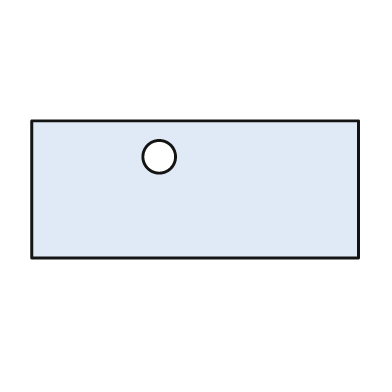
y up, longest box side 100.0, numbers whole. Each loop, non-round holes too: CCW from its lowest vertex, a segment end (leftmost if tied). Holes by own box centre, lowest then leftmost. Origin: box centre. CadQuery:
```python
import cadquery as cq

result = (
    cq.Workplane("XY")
    .moveTo(-50.0, -21.0)
    .lineTo(50.0, -21.0)
    .lineTo(50.0, 21.0)
    .lineTo(-50.0, 21.0)
    .close()
    .moveTo(-11.0, 10.0)
    .circle(5.0)
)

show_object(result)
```